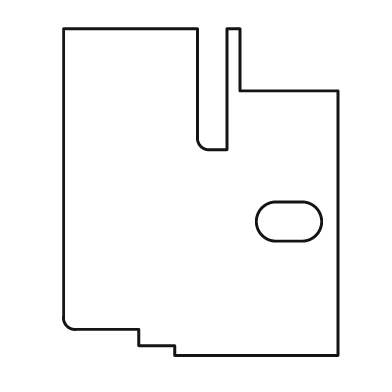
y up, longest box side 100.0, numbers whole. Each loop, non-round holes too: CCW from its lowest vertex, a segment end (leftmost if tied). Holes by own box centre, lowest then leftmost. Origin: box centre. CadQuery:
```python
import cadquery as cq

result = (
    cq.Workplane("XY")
    .moveTo(-8.0, -50.0)
    .lineTo(42.0, -50.0)
    .lineTo(42.0, 31.0)
    .lineTo(12.0, 31.0)
    .lineTo(12.0, 50.0)
    .lineTo(8.0, 50.0)
    .lineTo(8.0, 13.0)
    .lineTo(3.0, 13.0)
    .threePointArc((0.0, 14.0), (-1.0, 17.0))
    .lineTo(-1.0, 50.0)
    .lineTo(-42.0, 50.0)
    .lineTo(-42.0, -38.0)
    .threePointArc((-41.0, -41.0), (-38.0, -42.0))
    .lineTo(-19.0, -42.0)
    .lineTo(-19.0, -47.0)
    .lineTo(-8.0, -47.0)
    .close()
    .moveTo(23.0, -15.0)
    .lineTo(31.0, -15.0)
    .threePointArc((37.0, -9.0), (31.0, -3.0))
    .lineTo(23.0, -3.0)
    .threePointArc((17.0, -9.0), (23.0, -15.0))
    .close()
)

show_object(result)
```